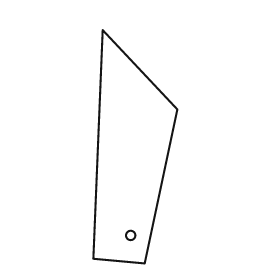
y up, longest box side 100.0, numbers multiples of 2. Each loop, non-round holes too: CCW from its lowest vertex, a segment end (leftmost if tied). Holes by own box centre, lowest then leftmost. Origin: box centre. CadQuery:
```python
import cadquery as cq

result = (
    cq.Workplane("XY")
    .moveTo(4.0, -50.0)
    .lineTo(18.0, 16.0)
    .lineTo(-14.0, 50.0)
    .lineTo(-18.0, -48.0)
    .close()
    .moveTo(-2.0, -38.0)
    .circle(2.0)
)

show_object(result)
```